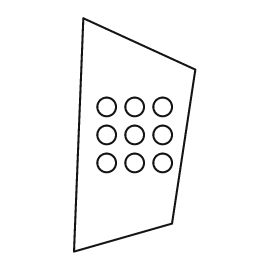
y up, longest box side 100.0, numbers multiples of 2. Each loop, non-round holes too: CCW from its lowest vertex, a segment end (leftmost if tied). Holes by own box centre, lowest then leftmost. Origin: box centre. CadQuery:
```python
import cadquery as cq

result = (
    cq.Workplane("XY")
    .moveTo(-26.0, -50.0)
    .lineTo(16.0, -38.0)
    .lineTo(26.0, 28.0)
    .lineTo(-22.0, 50.0)
    .close()
    .moveTo(-12.0, -12.0)
    .circle(4.0)
    .moveTo(0.0, -12.0)
    .circle(4.0)
    .moveTo(12.0, -12.0)
    .circle(4.0)
    .moveTo(-12.0, 0.0)
    .circle(4.0)
    .moveTo(0.0, 0.0)
    .circle(4.0)
    .moveTo(12.0, 0.0)
    .circle(4.0)
    .moveTo(-12.0, 12.0)
    .circle(4.0)
    .moveTo(0.0, 12.0)
    .circle(4.0)
    .moveTo(12.0, 12.0)
    .circle(4.0)
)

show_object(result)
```